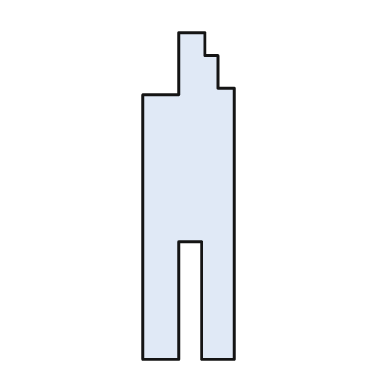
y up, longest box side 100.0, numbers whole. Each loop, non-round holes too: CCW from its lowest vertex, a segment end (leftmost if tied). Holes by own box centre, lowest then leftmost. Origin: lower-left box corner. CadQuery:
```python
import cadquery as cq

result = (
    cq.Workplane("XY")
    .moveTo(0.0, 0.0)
    .lineTo(11.0, 0.0)
    .lineTo(11.0, 36.0)
    .lineTo(18.0, 36.0)
    .lineTo(18.0, 0.0)
    .lineTo(28.0, 0.0)
    .lineTo(28.0, 83.0)
    .lineTo(23.0, 83.0)
    .lineTo(23.0, 93.0)
    .lineTo(19.0, 93.0)
    .lineTo(19.0, 100.0)
    .lineTo(11.0, 100.0)
    .lineTo(11.0, 81.0)
    .lineTo(0.0, 81.0)
    .close()
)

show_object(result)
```